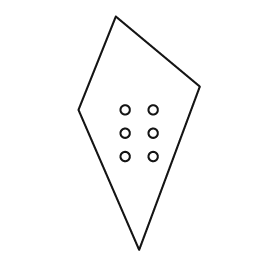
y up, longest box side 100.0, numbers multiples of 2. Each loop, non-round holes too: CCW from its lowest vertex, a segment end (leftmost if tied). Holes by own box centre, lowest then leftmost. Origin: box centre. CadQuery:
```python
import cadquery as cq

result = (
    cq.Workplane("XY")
    .moveTo(0.0, -50.0)
    .lineTo(26.0, 20.0)
    .lineTo(-10.0, 50.0)
    .lineTo(-26.0, 10.0)
    .close()
    .moveTo(-6.0, -10.0)
    .circle(2.0)
    .moveTo(6.0, -10.0)
    .circle(2.0)
    .moveTo(-6.0, 0.0)
    .circle(2.0)
    .moveTo(6.0, 0.0)
    .circle(2.0)
    .moveTo(-6.0, 10.0)
    .circle(2.0)
    .moveTo(6.0, 10.0)
    .circle(2.0)
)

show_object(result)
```